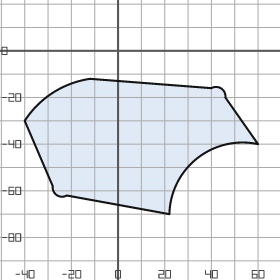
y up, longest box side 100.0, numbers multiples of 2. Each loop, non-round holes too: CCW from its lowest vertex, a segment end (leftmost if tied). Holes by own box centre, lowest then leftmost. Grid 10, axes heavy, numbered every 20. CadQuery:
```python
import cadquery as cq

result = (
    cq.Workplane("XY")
    .moveTo(22.0, -70.0)
    .threePointArc((34.0, -46.0), (60.0, -40.0))
    .lineTo(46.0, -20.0)
    .threePointArc((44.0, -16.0), (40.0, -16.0))
    .lineTo(-12.0, -12.0)
    .threePointArc((-28.0, -18.0), (-40.0, -30.0))
    .lineTo(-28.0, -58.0)
    .threePointArc((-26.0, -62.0), (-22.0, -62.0))
    .close()
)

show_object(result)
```